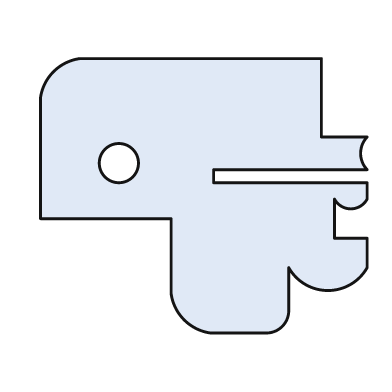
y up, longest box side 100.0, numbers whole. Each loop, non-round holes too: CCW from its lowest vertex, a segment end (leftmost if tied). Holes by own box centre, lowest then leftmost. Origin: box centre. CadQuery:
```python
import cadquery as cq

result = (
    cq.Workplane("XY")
    .moveTo(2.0, -42.0)
    .lineTo(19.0, -42.0)
    .threePointArc((24.0, -40.0), (26.0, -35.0))
    .lineTo(26.0, -22.0)
    .threePointArc((38.0, -29.0), (50.0, -22.0))
    .lineTo(50.0, -13.0)
    .lineTo(40.0, -13.0)
    .lineTo(40.0, -1.0)
    .threePointArc((45.0, -4.0), (50.0, -1.0))
    .lineTo(50.0, 4.0)
    .lineTo(3.0, 4.0)
    .lineTo(3.0, 8.0)
    .lineTo(50.0, 8.0)
    .threePointArc((48.0, 13.0), (50.0, 18.0))
    .lineTo(36.0, 18.0)
    .lineTo(36.0, 42.0)
    .lineTo(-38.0, 42.0)
    .threePointArc((-46.0, 38.0), (-50.0, 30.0))
    .lineTo(-50.0, -7.0)
    .lineTo(-10.0, -7.0)
    .lineTo(-10.0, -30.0)
    .threePointArc((-6.0, -38.0), (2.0, -42.0))
    .close()
    .moveTo(-26.0, 10.0)
    .circle(6.0)
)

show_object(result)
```